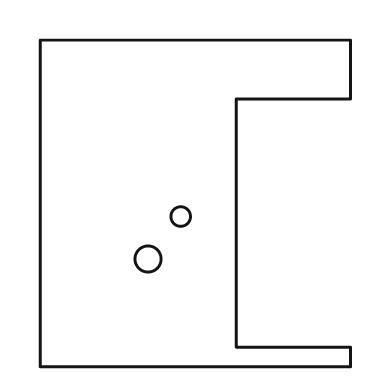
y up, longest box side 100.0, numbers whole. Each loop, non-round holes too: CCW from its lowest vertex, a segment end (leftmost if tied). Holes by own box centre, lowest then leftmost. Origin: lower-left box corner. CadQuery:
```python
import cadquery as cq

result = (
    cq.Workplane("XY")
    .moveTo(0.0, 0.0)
    .lineTo(95.0, 0.0)
    .lineTo(95.0, 6.0)
    .lineTo(60.0, 6.0)
    .lineTo(60.0, 82.0)
    .lineTo(95.0, 82.0)
    .lineTo(95.0, 100.0)
    .lineTo(0.0, 100.0)
    .close()
    .moveTo(33.0, 33.0)
    .circle(4.0)
    .moveTo(43.0, 46.0)
    .circle(3.0)
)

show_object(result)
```